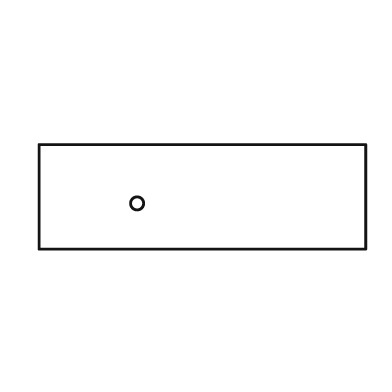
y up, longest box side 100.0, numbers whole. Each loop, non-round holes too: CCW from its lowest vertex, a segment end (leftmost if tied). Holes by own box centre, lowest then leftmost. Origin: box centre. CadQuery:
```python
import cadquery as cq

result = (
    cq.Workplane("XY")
    .moveTo(-50.0, -16.0)
    .lineTo(50.0, -16.0)
    .lineTo(50.0, 16.0)
    .lineTo(-50.0, 16.0)
    .close()
    .moveTo(-20.0, -2.0)
    .circle(2.0)
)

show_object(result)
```